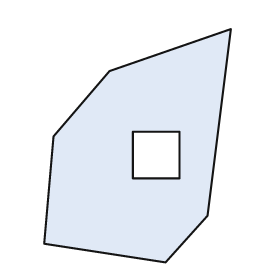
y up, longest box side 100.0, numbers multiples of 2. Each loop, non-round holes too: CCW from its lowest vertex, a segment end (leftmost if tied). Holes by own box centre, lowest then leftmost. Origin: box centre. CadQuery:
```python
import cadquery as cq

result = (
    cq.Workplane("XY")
    .moveTo(12.0, -50.0)
    .lineTo(30.0, -30.0)
    .lineTo(40.0, 50.0)
    .lineTo(-12.0, 32.0)
    .lineTo(-36.0, 4.0)
    .lineTo(-40.0, -42.0)
    .close()
    .moveTo(-2.0, -14.0)
    .lineTo(18.0, -14.0)
    .lineTo(18.0, 6.0)
    .lineTo(-2.0, 6.0)
    .close()
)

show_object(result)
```